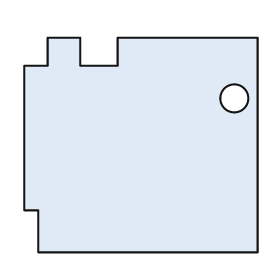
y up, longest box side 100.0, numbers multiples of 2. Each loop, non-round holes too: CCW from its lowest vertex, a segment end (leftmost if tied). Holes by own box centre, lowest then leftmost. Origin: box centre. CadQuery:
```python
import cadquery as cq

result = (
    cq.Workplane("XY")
    .moveTo(-44.0, -46.0)
    .lineTo(50.0, -46.0)
    .lineTo(50.0, 46.0)
    .lineTo(-10.0, 46.0)
    .lineTo(-10.0, 34.0)
    .lineTo(-26.0, 34.0)
    .lineTo(-26.0, 46.0)
    .lineTo(-40.0, 46.0)
    .lineTo(-40.0, 34.0)
    .lineTo(-50.0, 34.0)
    .lineTo(-50.0, -28.0)
    .lineTo(-44.0, -28.0)
    .close()
    .moveTo(40.0, 20.0)
    .circle(6.0)
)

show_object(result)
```